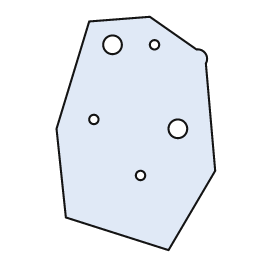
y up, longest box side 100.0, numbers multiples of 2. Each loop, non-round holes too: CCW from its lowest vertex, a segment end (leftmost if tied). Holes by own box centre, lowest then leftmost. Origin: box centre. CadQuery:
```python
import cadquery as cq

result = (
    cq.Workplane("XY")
    .moveTo(14.0, -50.0)
    .lineTo(34.0, -16.0)
    .lineTo(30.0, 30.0)
    .threePointArc((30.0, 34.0), (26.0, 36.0))
    .lineTo(6.0, 50.0)
    .lineTo(-20.0, 48.0)
    .lineTo(-34.0, 2.0)
    .lineTo(-30.0, -36.0)
    .close()
    .moveTo(2.0, -18.0)
    .circle(2.0)
    .moveTo(18.0, 2.0)
    .circle(4.0)
    .moveTo(-18.0, 6.0)
    .circle(2.0)
    .moveTo(-10.0, 38.0)
    .circle(4.0)
    .moveTo(8.0, 38.0)
    .circle(2.0)
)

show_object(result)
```